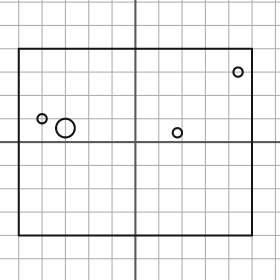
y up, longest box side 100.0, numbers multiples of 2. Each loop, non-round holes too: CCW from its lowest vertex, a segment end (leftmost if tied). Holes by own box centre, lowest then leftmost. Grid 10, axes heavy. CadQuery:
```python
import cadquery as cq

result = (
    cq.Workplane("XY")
    .moveTo(-50.0, -40.0)
    .lineTo(50.0, -40.0)
    .lineTo(50.0, 40.0)
    .lineTo(-50.0, 40.0)
    .close()
    .moveTo(18.0, 4.0)
    .circle(2.0)
    .moveTo(-30.0, 6.0)
    .circle(4.0)
    .moveTo(-40.0, 10.0)
    .circle(2.0)
    .moveTo(44.0, 30.0)
    .circle(2.0)
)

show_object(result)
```